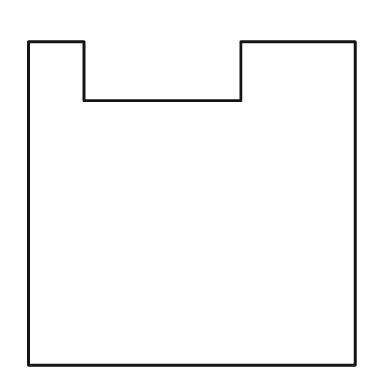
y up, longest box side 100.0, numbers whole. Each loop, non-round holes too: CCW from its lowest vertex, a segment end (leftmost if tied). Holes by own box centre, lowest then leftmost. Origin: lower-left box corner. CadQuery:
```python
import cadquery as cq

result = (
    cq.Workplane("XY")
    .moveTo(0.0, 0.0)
    .lineTo(100.0, 0.0)
    .lineTo(100.0, 99.0)
    .lineTo(65.0, 99.0)
    .lineTo(65.0, 81.0)
    .lineTo(17.0, 81.0)
    .lineTo(17.0, 99.0)
    .lineTo(0.0, 99.0)
    .close()
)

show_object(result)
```